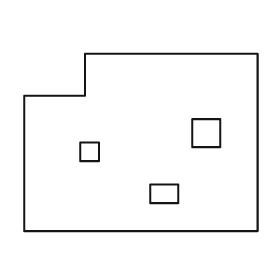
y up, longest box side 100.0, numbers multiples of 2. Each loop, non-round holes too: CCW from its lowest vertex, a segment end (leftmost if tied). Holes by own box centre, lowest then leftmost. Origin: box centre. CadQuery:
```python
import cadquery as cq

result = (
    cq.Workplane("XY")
    .moveTo(-50.0, -38.0)
    .lineTo(50.0, -38.0)
    .lineTo(50.0, 38.0)
    .lineTo(-24.0, 38.0)
    .lineTo(-24.0, 20.0)
    .lineTo(-50.0, 20.0)
    .close()
    .moveTo(4.0, -26.0)
    .lineTo(16.0, -26.0)
    .lineTo(16.0, -18.0)
    .lineTo(4.0, -18.0)
    .close()
    .moveTo(-26.0, -8.0)
    .lineTo(-18.0, -8.0)
    .lineTo(-18.0, 0.0)
    .lineTo(-26.0, 0.0)
    .close()
    .moveTo(22.0, -2.0)
    .lineTo(34.0, -2.0)
    .lineTo(34.0, 10.0)
    .lineTo(22.0, 10.0)
    .close()
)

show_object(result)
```